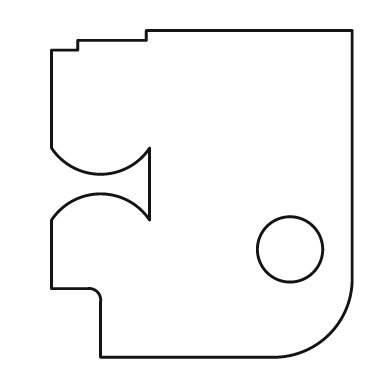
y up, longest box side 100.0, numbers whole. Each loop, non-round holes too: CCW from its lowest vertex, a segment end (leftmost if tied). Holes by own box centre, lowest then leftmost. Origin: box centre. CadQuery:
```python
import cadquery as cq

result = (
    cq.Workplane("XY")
    .moveTo(-31.0, -50.0)
    .lineTo(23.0, -50.0)
    .threePointArc((39.0, -43.0), (46.0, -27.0))
    .lineTo(46.0, 50.0)
    .lineTo(-17.0, 50.0)
    .lineTo(-17.0, 47.0)
    .lineTo(-38.0, 47.0)
    .lineTo(-38.0, 44.0)
    .lineTo(-46.0, 44.0)
    .lineTo(-46.0, 14.0)
    .threePointArc((-31.0, 6.0), (-16.0, 14.0))
    .lineTo(-16.0, -8.0)
    .threePointArc((-31.0, 0.0), (-46.0, -8.0))
    .lineTo(-46.0, -29.0)
    .lineTo(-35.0, -29.0)
    .threePointArc((-32.0, -30.0), (-31.0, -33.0))
    .close()
    .moveTo(27.0, -17.0)
    .circle(10.0)
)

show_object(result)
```